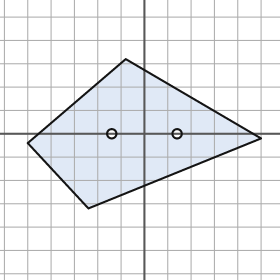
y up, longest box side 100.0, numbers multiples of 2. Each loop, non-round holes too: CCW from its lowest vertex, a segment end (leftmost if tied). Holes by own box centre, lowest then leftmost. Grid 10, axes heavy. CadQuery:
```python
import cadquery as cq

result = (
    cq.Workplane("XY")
    .moveTo(-24.0, -32.0)
    .lineTo(50.0, -2.0)
    .lineTo(-8.0, 32.0)
    .lineTo(-50.0, -4.0)
    .close()
    .moveTo(-14.0, 0.0)
    .circle(2.0)
    .moveTo(14.0, 0.0)
    .circle(2.0)
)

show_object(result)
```